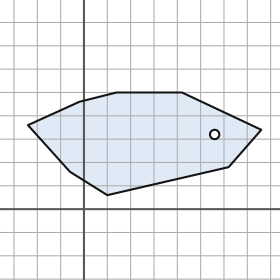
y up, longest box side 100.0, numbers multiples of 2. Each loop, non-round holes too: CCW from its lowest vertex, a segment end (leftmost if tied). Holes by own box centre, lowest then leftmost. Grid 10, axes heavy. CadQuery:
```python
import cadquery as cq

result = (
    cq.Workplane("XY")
    .moveTo(10.0, 6.0)
    .lineTo(62.0, 18.0)
    .lineTo(76.0, 34.0)
    .lineTo(42.0, 50.0)
    .lineTo(14.0, 50.0)
    .lineTo(-2.0, 46.0)
    .lineTo(-24.0, 36.0)
    .lineTo(-6.0, 16.0)
    .close()
    .moveTo(56.0, 32.0)
    .circle(2.0)
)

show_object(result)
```